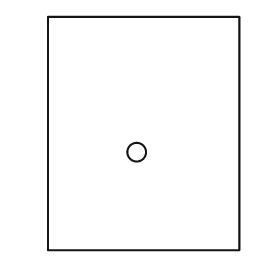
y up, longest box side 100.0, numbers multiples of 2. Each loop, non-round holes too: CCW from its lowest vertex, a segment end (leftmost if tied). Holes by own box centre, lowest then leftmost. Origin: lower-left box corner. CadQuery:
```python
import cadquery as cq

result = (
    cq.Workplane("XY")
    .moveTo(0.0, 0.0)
    .lineTo(82.0, 0.0)
    .lineTo(82.0, 100.0)
    .lineTo(0.0, 100.0)
    .close()
    .moveTo(38.0, 42.0)
    .circle(4.0)
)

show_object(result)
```